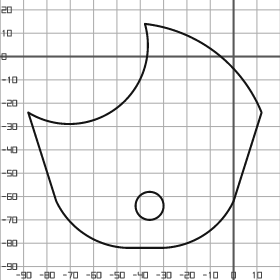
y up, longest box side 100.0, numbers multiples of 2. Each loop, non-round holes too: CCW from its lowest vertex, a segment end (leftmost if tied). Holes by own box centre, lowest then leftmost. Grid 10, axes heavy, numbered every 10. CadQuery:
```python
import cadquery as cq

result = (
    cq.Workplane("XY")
    .moveTo(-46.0, -82.0)
    .lineTo(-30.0, -82.0)
    .threePointArc((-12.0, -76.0), (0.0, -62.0))
    .lineTo(12.0, -24.0)
    .threePointArc((-8.0, 2.0), (-38.0, 14.0))
    .threePointArc((-50.0, -22.0), (-88.0, -24.0))
    .lineTo(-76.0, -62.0)
    .threePointArc((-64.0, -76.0), (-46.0, -82.0))
    .close()
    .moveTo(-36.0, -64.0)
    .circle(6.0)
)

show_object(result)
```